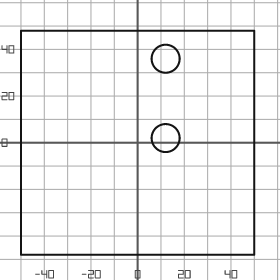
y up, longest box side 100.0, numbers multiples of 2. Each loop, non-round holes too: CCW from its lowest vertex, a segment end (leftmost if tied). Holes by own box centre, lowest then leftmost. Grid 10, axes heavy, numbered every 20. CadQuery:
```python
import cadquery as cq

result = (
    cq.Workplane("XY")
    .moveTo(-50.0, -48.0)
    .lineTo(50.0, -48.0)
    .lineTo(50.0, 48.0)
    .lineTo(-50.0, 48.0)
    .close()
    .moveTo(12.0, 2.0)
    .circle(6.0)
    .moveTo(12.0, 36.0)
    .circle(6.0)
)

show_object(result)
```